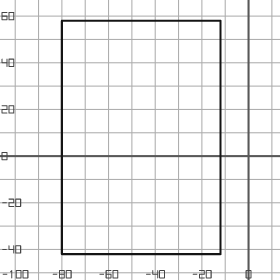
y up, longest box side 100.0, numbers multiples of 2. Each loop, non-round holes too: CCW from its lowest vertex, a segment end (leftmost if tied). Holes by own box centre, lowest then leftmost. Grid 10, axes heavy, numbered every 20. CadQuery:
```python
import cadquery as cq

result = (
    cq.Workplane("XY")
    .moveTo(-80.0, -42.0)
    .lineTo(-12.0, -42.0)
    .lineTo(-12.0, 58.0)
    .lineTo(-80.0, 58.0)
    .close()
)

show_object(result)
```